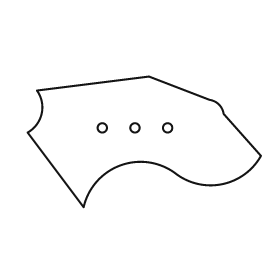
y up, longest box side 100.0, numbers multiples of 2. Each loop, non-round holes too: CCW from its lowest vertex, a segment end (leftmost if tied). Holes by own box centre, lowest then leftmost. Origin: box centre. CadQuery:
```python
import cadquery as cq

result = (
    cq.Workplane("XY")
    .moveTo(-26.0, -28.0)
    .threePointArc((-10.0, -10.0), (14.0, -14.0))
    .threePointArc((34.0, -18.0), (50.0, -6.0))
    .lineTo(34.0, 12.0)
    .threePointArc((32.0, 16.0), (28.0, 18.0))
    .lineTo(2.0, 28.0)
    .lineTo(-46.0, 22.0)
    .threePointArc((-44.0, 12.0), (-50.0, 4.0))
    .close()
    .moveTo(-18.0, 6.0)
    .circle(2.0)
    .moveTo(-4.0, 6.0)
    .circle(2.0)
    .moveTo(10.0, 6.0)
    .circle(2.0)
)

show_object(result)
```